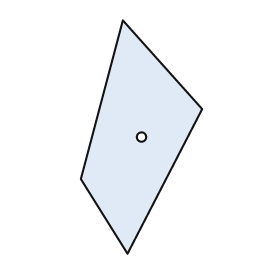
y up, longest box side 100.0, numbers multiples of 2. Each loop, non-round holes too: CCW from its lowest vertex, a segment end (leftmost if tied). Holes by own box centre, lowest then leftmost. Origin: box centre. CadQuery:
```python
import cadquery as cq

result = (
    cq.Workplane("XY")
    .moveTo(-6.0, -50.0)
    .lineTo(26.0, 12.0)
    .lineTo(-8.0, 50.0)
    .lineTo(-26.0, -18.0)
    .close()
    .moveTo(0.0, 0.0)
    .circle(2.0)
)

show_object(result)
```